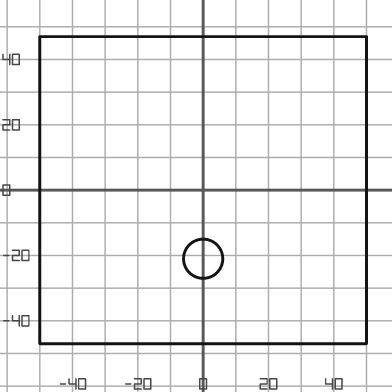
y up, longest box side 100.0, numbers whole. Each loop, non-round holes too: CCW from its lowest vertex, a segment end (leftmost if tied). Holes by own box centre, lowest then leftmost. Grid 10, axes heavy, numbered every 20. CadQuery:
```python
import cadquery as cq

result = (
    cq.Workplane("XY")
    .moveTo(-50.0, -47.0)
    .lineTo(50.0, -47.0)
    .lineTo(50.0, 47.0)
    .lineTo(-50.0, 47.0)
    .close()
    .moveTo(0.0, -21.0)
    .circle(6.0)
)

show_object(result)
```